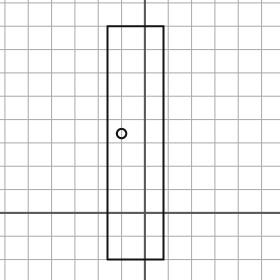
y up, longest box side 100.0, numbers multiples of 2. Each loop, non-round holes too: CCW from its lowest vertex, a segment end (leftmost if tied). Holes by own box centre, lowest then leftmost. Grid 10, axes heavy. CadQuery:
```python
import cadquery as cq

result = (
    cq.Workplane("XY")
    .moveTo(-16.0, -20.0)
    .lineTo(8.0, -20.0)
    .lineTo(8.0, 80.0)
    .lineTo(-16.0, 80.0)
    .close()
    .moveTo(-10.0, 34.0)
    .circle(2.0)
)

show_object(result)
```